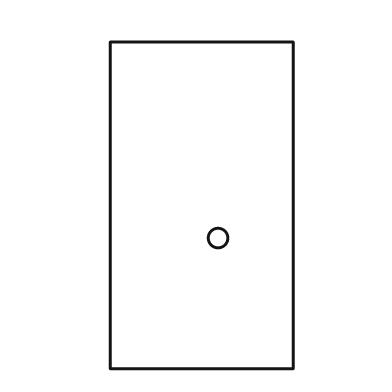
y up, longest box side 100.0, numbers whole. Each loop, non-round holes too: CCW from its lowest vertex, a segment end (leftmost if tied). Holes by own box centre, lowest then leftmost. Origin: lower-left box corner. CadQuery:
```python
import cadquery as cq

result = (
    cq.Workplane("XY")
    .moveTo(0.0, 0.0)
    .lineTo(56.0, 0.0)
    .lineTo(56.0, 100.0)
    .lineTo(0.0, 100.0)
    .close()
    .moveTo(33.0, 40.0)
    .circle(3.0)
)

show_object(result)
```